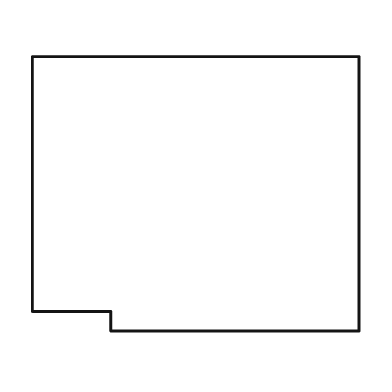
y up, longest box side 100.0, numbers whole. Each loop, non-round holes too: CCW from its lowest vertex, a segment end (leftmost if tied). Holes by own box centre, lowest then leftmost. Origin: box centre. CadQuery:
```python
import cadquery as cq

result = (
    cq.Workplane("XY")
    .moveTo(-26.0, -42.0)
    .lineTo(50.0, -42.0)
    .lineTo(50.0, 42.0)
    .lineTo(-50.0, 42.0)
    .lineTo(-50.0, -36.0)
    .lineTo(-26.0, -36.0)
    .close()
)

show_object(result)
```